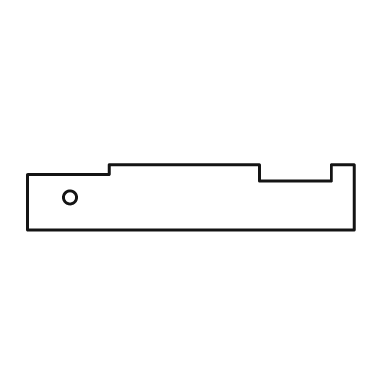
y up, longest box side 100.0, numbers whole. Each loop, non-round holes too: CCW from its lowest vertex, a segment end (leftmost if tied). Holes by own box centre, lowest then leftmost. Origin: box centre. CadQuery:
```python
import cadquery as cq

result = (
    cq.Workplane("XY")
    .moveTo(-50.0, -10.0)
    .lineTo(50.0, -10.0)
    .lineTo(50.0, 10.0)
    .lineTo(43.0, 10.0)
    .lineTo(43.0, 5.0)
    .lineTo(21.0, 5.0)
    .lineTo(21.0, 10.0)
    .lineTo(-25.0, 10.0)
    .lineTo(-25.0, 7.0)
    .lineTo(-50.0, 7.0)
    .close()
    .moveTo(-37.0, 0.0)
    .circle(2.0)
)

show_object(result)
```